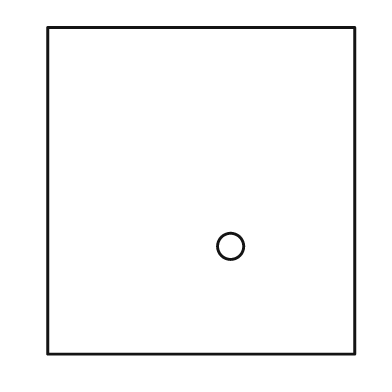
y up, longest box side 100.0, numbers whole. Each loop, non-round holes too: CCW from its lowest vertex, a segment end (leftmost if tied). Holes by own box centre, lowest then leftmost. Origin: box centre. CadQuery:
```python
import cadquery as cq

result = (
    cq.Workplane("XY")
    .moveTo(-47.0, -50.0)
    .lineTo(47.0, -50.0)
    .lineTo(47.0, 50.0)
    .lineTo(-47.0, 50.0)
    .close()
    .moveTo(9.0, -17.0)
    .circle(4.0)
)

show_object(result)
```